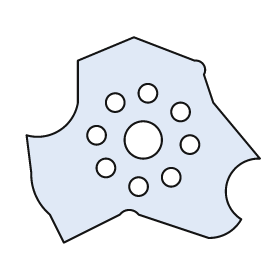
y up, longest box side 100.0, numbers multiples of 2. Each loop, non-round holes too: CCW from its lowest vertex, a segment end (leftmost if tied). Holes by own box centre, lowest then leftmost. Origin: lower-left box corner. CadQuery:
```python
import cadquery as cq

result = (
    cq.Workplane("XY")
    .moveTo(16.0, 0.0)
    .lineTo(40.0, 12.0)
    .threePointArc((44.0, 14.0), (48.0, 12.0))
    .lineTo(78.0, 2.0)
    .threePointArc((86.0, 4.0), (92.0, 10.0))
    .threePointArc((86.0, 26.0), (100.0, 36.0))
    .lineTo(80.0, 60.0)
    .lineTo(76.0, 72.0)
    .threePointArc((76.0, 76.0), (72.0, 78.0))
    .lineTo(46.0, 88.0)
    .lineTo(22.0, 78.0)
    .lineTo(22.0, 60.0)
    .threePointArc((14.0, 48.0), (0.0, 46.0))
    .lineTo(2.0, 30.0)
    .threePointArc((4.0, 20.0), (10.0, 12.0))
    .close()
    .moveTo(48.0, 24.0)
    .circle(4.0)
    .moveTo(62.0, 28.0)
    .circle(4.0)
    .moveTo(34.0, 32.0)
    .circle(4.0)
    .moveTo(70.0, 42.0)
    .circle(4.0)
    .moveTo(50.0, 44.0)
    .circle(8.0)
    .moveTo(30.0, 46.0)
    .circle(4.0)
    .moveTo(66.0, 56.0)
    .circle(4.0)
    .moveTo(38.0, 60.0)
    .circle(4.0)
    .moveTo(52.0, 64.0)
    .circle(4.0)
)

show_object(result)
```